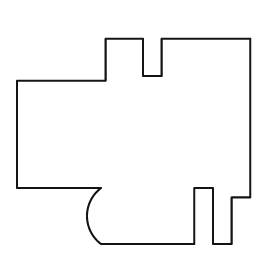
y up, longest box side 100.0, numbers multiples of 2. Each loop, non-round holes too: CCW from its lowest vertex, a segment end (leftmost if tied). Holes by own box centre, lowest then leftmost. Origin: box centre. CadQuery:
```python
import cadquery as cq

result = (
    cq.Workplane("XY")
    .moveTo(-14.0, -44.0)
    .lineTo(26.0, -44.0)
    .lineTo(26.0, -20.0)
    .lineTo(34.0, -20.0)
    .lineTo(34.0, -44.0)
    .lineTo(42.0, -44.0)
    .lineTo(42.0, -24.0)
    .lineTo(50.0, -24.0)
    .lineTo(50.0, 44.0)
    .lineTo(12.0, 44.0)
    .lineTo(12.0, 28.0)
    .lineTo(4.0, 28.0)
    .lineTo(4.0, 44.0)
    .lineTo(-12.0, 44.0)
    .lineTo(-12.0, 26.0)
    .lineTo(-50.0, 26.0)
    .lineTo(-50.0, -20.0)
    .lineTo(-14.0, -20.0)
    .threePointArc((-20.0, -32.0), (-14.0, -44.0))
    .close()
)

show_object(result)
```